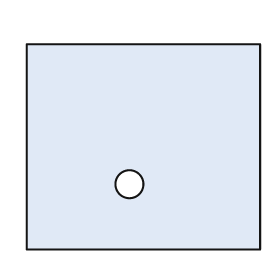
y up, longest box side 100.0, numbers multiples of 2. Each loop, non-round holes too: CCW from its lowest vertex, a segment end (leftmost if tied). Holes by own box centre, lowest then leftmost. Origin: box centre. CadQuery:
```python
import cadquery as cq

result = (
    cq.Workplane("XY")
    .moveTo(-50.0, -44.0)
    .lineTo(50.0, -44.0)
    .lineTo(50.0, 44.0)
    .lineTo(-50.0, 44.0)
    .close()
    .moveTo(-6.0, -16.0)
    .circle(6.0)
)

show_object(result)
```